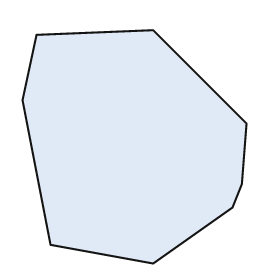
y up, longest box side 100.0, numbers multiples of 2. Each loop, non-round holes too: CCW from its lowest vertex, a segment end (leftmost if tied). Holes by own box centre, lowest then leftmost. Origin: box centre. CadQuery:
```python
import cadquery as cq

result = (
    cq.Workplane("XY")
    .moveTo(8.0, -50.0)
    .lineTo(42.0, -26.0)
    .lineTo(46.0, -16.0)
    .lineTo(48.0, 10.0)
    .lineTo(8.0, 50.0)
    .lineTo(-42.0, 48.0)
    .lineTo(-48.0, 20.0)
    .lineTo(-36.0, -42.0)
    .close()
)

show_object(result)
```